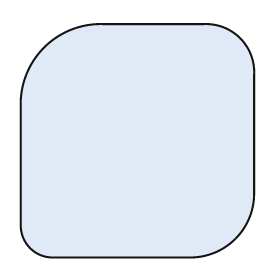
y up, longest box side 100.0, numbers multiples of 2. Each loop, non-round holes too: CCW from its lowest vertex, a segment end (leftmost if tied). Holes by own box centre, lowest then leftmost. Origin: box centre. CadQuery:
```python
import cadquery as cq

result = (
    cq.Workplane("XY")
    .moveTo(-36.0, -50.0)
    .lineTo(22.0, -50.0)
    .threePointArc((42.0, -42.0), (50.0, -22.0))
    .lineTo(50.0, 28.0)
    .threePointArc((44.0, 44.0), (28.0, 50.0))
    .lineTo(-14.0, 50.0)
    .threePointArc((-40.0, 40.0), (-50.0, 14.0))
    .lineTo(-50.0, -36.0)
    .threePointArc((-46.0, -46.0), (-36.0, -50.0))
    .close()
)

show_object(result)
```